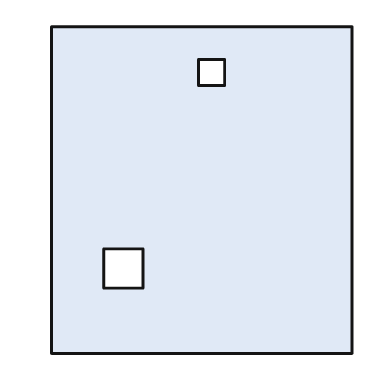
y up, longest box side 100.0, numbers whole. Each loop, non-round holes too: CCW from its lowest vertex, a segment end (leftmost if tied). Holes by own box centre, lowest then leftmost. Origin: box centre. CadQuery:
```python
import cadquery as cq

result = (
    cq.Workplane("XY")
    .moveTo(-46.0, -50.0)
    .lineTo(46.0, -50.0)
    .lineTo(46.0, 50.0)
    .lineTo(-46.0, 50.0)
    .close()
    .moveTo(-30.0, -30.0)
    .lineTo(-18.0, -30.0)
    .lineTo(-18.0, -18.0)
    .lineTo(-30.0, -18.0)
    .close()
    .moveTo(-1.0, 32.0)
    .lineTo(7.0, 32.0)
    .lineTo(7.0, 40.0)
    .lineTo(-1.0, 40.0)
    .close()
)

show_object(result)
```